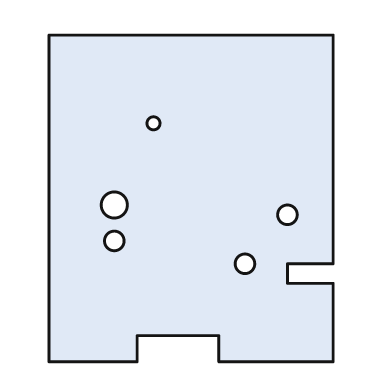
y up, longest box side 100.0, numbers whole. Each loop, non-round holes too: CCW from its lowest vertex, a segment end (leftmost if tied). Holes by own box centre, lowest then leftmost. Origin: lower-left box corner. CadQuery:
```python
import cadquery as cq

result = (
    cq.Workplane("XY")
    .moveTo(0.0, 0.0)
    .lineTo(27.0, 0.0)
    .lineTo(27.0, 8.0)
    .lineTo(52.0, 8.0)
    .lineTo(52.0, 0.0)
    .lineTo(87.0, 0.0)
    .lineTo(87.0, 24.0)
    .lineTo(73.0, 24.0)
    .lineTo(73.0, 30.0)
    .lineTo(87.0, 30.0)
    .lineTo(87.0, 100.0)
    .lineTo(0.0, 100.0)
    .close()
    .moveTo(60.0, 30.0)
    .circle(3.0)
    .moveTo(20.0, 37.0)
    .circle(3.0)
    .moveTo(73.0, 45.0)
    .circle(3.0)
    .moveTo(20.0, 48.0)
    .circle(4.0)
    .moveTo(32.0, 73.0)
    .circle(2.0)
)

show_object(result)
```